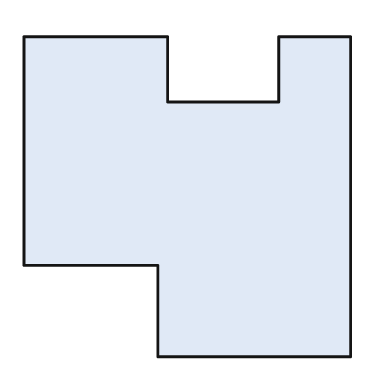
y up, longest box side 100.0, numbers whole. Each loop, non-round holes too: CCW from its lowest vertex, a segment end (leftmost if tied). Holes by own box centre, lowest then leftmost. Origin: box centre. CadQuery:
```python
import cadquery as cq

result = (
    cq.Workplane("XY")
    .moveTo(-9.0, -49.0)
    .lineTo(50.0, -49.0)
    .lineTo(50.0, 49.0)
    .lineTo(28.0, 49.0)
    .lineTo(28.0, 29.0)
    .lineTo(-6.0, 29.0)
    .lineTo(-6.0, 49.0)
    .lineTo(-50.0, 49.0)
    .lineTo(-50.0, -21.0)
    .lineTo(-9.0, -21.0)
    .close()
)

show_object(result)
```